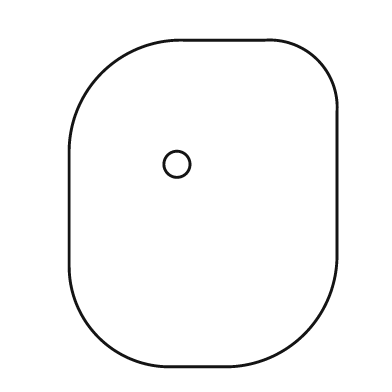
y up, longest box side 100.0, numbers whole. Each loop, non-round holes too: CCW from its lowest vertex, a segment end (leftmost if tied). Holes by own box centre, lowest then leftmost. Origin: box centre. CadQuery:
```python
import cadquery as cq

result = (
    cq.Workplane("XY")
    .moveTo(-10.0, -50.0)
    .lineTo(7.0, -50.0)
    .threePointArc((31.0, -40.0), (41.0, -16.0))
    .lineTo(41.0, 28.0)
    .threePointArc((35.0, 44.0), (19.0, 50.0))
    .lineTo(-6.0, 50.0)
    .threePointArc((-31.0, 40.0), (-41.0, 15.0))
    .lineTo(-41.0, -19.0)
    .threePointArc((-32.0, -41.0), (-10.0, -50.0))
    .close()
    .moveTo(-8.0, 12.0)
    .circle(4.0)
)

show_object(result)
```